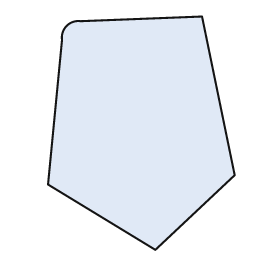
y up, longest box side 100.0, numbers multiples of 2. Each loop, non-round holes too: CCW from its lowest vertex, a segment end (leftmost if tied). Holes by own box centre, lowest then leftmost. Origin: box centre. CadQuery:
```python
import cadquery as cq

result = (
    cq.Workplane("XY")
    .moveTo(6.0, -50.0)
    .lineTo(40.0, -18.0)
    .lineTo(26.0, 50.0)
    .lineTo(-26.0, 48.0)
    .threePointArc((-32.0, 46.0), (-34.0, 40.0))
    .lineTo(-40.0, -22.0)
    .close()
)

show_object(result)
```